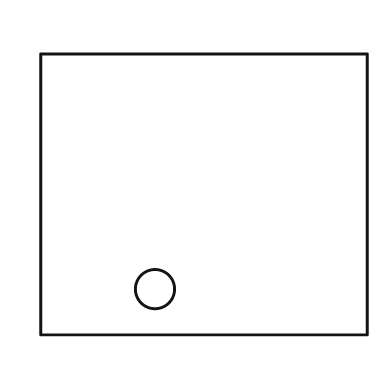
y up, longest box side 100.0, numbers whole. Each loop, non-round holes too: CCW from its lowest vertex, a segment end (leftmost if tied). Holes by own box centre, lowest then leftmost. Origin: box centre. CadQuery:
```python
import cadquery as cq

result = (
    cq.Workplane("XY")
    .moveTo(-50.0, -43.0)
    .lineTo(50.0, -43.0)
    .lineTo(50.0, 43.0)
    .lineTo(-50.0, 43.0)
    .close()
    .moveTo(-15.0, -29.0)
    .circle(6.0)
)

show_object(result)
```